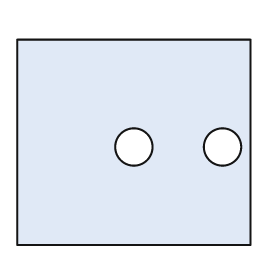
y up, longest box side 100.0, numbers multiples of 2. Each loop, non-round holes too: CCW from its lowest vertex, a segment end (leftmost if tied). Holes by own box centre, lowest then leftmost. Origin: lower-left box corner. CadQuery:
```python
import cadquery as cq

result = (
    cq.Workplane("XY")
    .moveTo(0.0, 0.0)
    .lineTo(100.0, 0.0)
    .lineTo(100.0, 88.0)
    .lineTo(0.0, 88.0)
    .close()
    .moveTo(50.0, 42.0)
    .circle(8.0)
    .moveTo(88.0, 42.0)
    .circle(8.0)
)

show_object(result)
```